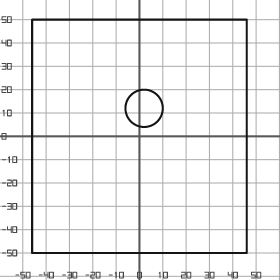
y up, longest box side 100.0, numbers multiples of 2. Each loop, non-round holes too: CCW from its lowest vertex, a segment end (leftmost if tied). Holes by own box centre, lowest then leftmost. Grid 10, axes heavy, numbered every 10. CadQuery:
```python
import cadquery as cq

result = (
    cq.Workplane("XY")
    .moveTo(-46.0, -50.0)
    .lineTo(46.0, -50.0)
    .lineTo(46.0, 50.0)
    .lineTo(-46.0, 50.0)
    .close()
    .moveTo(2.0, 12.0)
    .circle(8.0)
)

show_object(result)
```